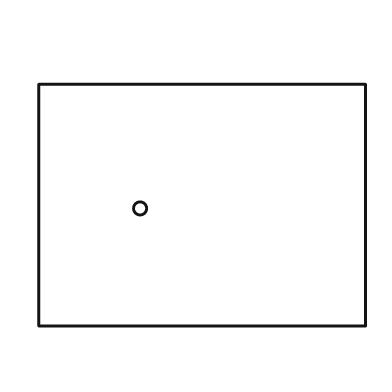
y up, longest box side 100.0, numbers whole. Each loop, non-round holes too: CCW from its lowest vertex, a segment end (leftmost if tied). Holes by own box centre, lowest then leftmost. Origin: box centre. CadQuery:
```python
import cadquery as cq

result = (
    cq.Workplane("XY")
    .moveTo(-50.0, -37.0)
    .lineTo(50.0, -37.0)
    .lineTo(50.0, 37.0)
    .lineTo(-50.0, 37.0)
    .close()
    .moveTo(-19.0, -1.0)
    .circle(2.0)
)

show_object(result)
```